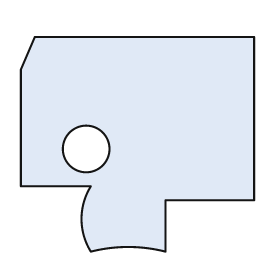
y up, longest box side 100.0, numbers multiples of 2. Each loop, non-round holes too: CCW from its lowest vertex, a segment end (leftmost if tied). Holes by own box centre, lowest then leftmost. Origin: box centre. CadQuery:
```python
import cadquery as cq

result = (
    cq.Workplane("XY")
    .moveTo(-20.0, -46.0)
    .threePointArc((-4.0, -44.0), (12.0, -46.0))
    .lineTo(12.0, -24.0)
    .lineTo(50.0, -24.0)
    .lineTo(50.0, 46.0)
    .lineTo(-44.0, 46.0)
    .lineTo(-50.0, 32.0)
    .lineTo(-50.0, -18.0)
    .lineTo(-20.0, -18.0)
    .threePointArc((-24.0, -32.0), (-20.0, -46.0))
    .close()
    .moveTo(-22.0, -2.0)
    .circle(10.0)
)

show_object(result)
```